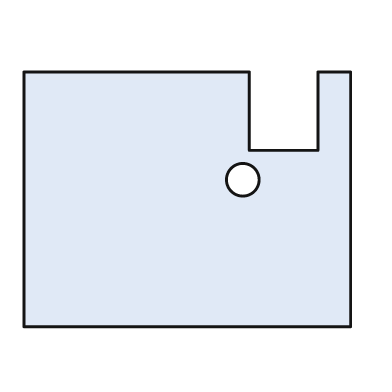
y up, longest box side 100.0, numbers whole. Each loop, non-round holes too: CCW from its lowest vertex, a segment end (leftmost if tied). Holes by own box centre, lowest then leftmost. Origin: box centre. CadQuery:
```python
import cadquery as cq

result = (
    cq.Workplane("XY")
    .moveTo(-50.0, -39.0)
    .lineTo(50.0, -39.0)
    .lineTo(50.0, 39.0)
    .lineTo(40.0, 39.0)
    .lineTo(40.0, 15.0)
    .lineTo(19.0, 15.0)
    .lineTo(19.0, 39.0)
    .lineTo(-50.0, 39.0)
    .close()
    .moveTo(17.0, 6.0)
    .circle(5.0)
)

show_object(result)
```